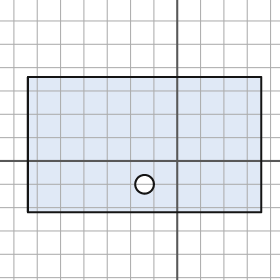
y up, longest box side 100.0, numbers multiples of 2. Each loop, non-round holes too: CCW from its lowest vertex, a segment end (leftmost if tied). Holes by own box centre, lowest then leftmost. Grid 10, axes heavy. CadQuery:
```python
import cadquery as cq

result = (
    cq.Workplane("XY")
    .moveTo(-64.0, -22.0)
    .lineTo(36.0, -22.0)
    .lineTo(36.0, 36.0)
    .lineTo(-64.0, 36.0)
    .close()
    .moveTo(-14.0, -10.0)
    .circle(4.0)
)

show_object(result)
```